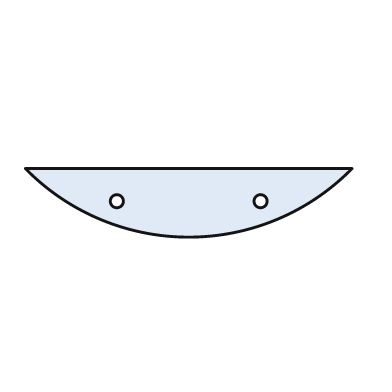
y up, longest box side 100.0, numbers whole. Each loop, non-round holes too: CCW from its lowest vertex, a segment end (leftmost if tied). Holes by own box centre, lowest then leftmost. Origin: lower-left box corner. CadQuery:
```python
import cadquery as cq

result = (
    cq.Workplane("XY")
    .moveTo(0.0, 21.0)
    .threePointArc((50.0, 0.0), (100.0, 21.0))
    .close()
    .moveTo(28.0, 11.0)
    .circle(2.0)
    .moveTo(72.0, 11.0)
    .circle(2.0)
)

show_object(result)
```